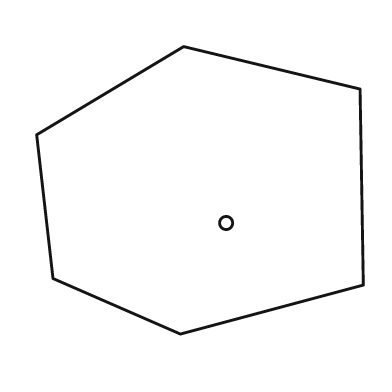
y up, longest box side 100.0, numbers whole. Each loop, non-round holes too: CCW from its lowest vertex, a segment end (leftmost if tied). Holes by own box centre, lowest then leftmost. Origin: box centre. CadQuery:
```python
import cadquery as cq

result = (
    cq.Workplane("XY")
    .moveTo(-6.0, -44.0)
    .lineTo(50.0, -29.0)
    .lineTo(49.0, 31.0)
    .lineTo(-5.0, 44.0)
    .lineTo(-50.0, 17.0)
    .lineTo(-45.0, -27.0)
    .close()
    .moveTo(8.0, -10.0)
    .circle(2.0)
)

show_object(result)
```